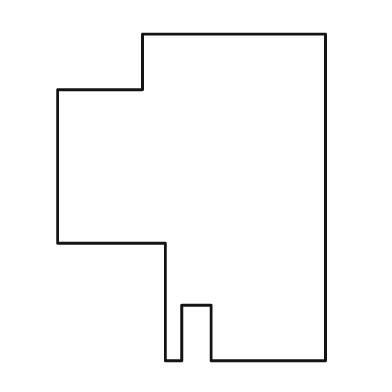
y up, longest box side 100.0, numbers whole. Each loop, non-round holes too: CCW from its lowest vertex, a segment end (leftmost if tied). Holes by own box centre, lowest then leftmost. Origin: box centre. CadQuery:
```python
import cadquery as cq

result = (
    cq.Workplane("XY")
    .moveTo(-8.0, -50.0)
    .lineTo(-3.0, -50.0)
    .lineTo(-3.0, -33.0)
    .lineTo(6.0, -33.0)
    .lineTo(6.0, -50.0)
    .lineTo(41.0, -50.0)
    .lineTo(41.0, 50.0)
    .lineTo(-15.0, 50.0)
    .lineTo(-15.0, 33.0)
    .lineTo(-41.0, 33.0)
    .lineTo(-41.0, -14.0)
    .lineTo(-8.0, -14.0)
    .close()
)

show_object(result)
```